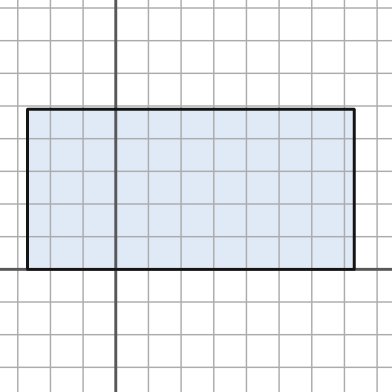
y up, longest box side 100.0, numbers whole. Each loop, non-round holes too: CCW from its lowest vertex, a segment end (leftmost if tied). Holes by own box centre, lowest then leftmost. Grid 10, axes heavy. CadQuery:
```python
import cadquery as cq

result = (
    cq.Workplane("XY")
    .moveTo(-27.0, 0.0)
    .lineTo(73.0, 0.0)
    .lineTo(73.0, 49.0)
    .lineTo(-27.0, 49.0)
    .close()
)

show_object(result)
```